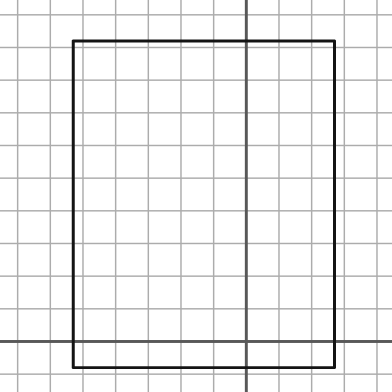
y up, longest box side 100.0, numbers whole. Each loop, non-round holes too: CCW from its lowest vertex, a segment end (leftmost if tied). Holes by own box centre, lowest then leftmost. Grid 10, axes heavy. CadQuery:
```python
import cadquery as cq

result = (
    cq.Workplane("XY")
    .moveTo(-53.0, -8.0)
    .lineTo(27.0, -8.0)
    .lineTo(27.0, 92.0)
    .lineTo(-53.0, 92.0)
    .close()
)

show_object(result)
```